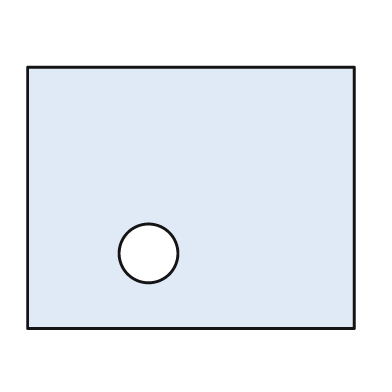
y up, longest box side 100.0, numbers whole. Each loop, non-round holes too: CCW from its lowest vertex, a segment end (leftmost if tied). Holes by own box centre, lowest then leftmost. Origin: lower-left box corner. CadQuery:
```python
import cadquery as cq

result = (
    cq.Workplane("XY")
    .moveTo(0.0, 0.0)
    .lineTo(100.0, 0.0)
    .lineTo(100.0, 80.0)
    .lineTo(0.0, 80.0)
    .close()
    .moveTo(37.0, 23.0)
    .circle(9.0)
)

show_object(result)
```